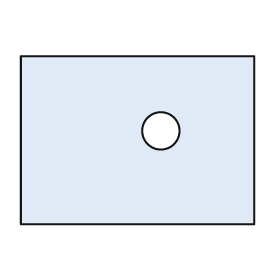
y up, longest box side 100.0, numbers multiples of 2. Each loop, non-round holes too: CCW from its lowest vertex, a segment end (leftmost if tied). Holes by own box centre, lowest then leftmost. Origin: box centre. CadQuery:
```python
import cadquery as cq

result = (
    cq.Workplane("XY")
    .moveTo(-50.0, -36.0)
    .lineTo(50.0, -36.0)
    .lineTo(50.0, 36.0)
    .lineTo(-50.0, 36.0)
    .close()
    .moveTo(10.0, 4.0)
    .circle(8.0)
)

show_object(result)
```